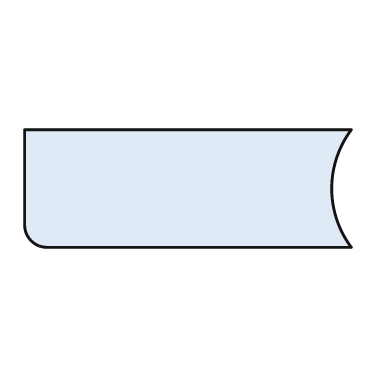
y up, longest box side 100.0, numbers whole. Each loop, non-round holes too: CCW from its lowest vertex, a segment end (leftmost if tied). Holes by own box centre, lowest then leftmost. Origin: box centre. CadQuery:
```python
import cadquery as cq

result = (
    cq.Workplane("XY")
    .moveTo(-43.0, -18.0)
    .lineTo(50.0, -18.0)
    .threePointArc((44.0, 0.0), (50.0, 18.0))
    .lineTo(-50.0, 18.0)
    .lineTo(-50.0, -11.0)
    .threePointArc((-48.0, -16.0), (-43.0, -18.0))
    .close()
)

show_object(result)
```